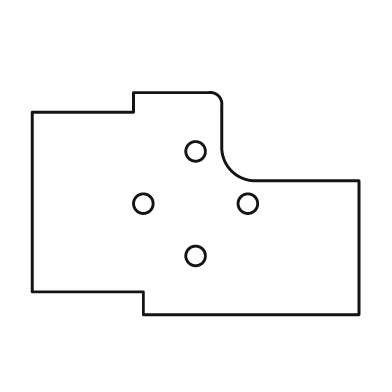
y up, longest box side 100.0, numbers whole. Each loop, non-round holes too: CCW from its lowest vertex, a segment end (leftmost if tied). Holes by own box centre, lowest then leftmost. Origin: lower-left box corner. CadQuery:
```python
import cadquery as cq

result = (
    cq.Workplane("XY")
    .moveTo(34.0, 0.0)
    .lineTo(100.0, 0.0)
    .lineTo(100.0, 41.0)
    .lineTo(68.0, 41.0)
    .threePointArc((61.0, 44.0), (58.0, 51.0))
    .lineTo(58.0, 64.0)
    .threePointArc((57.0, 67.0), (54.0, 68.0))
    .lineTo(31.0, 68.0)
    .lineTo(31.0, 62.0)
    .lineTo(0.0, 62.0)
    .lineTo(0.0, 7.0)
    .lineTo(34.0, 7.0)
    .close()
    .moveTo(50.0, 18.0)
    .circle(3.0)
    .moveTo(34.0, 34.0)
    .circle(3.0)
    .moveTo(66.0, 34.0)
    .circle(3.0)
    .moveTo(50.0, 50.0)
    .circle(3.0)
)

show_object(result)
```